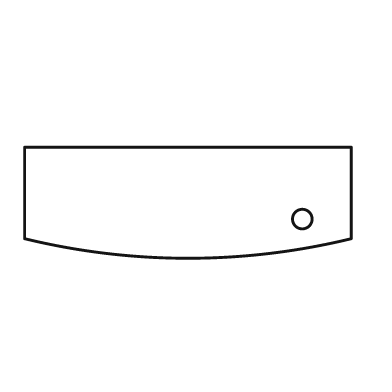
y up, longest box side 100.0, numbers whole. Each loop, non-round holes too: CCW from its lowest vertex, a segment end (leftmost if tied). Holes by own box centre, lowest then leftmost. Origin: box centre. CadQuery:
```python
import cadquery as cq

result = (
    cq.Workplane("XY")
    .moveTo(-50.0, -11.0)
    .threePointArc((0.0, -17.0), (50.0, -11.0))
    .lineTo(50.0, 17.0)
    .lineTo(-50.0, 17.0)
    .close()
    .moveTo(35.0, -5.0)
    .circle(3.0)
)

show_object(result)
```